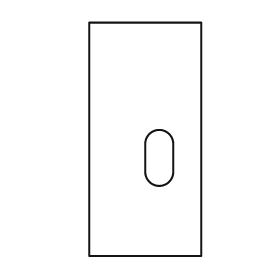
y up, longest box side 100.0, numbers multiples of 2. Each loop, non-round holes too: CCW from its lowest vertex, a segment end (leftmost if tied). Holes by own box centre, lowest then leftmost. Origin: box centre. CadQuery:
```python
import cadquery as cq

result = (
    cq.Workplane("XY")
    .moveTo(-24.0, -50.0)
    .lineTo(24.0, -50.0)
    .lineTo(24.0, 50.0)
    .lineTo(-24.0, 50.0)
    .close()
    .moveTo(0.0, -14.0)
    .threePointArc((6.0, -20.0), (12.0, -14.0))
    .lineTo(12.0, -2.0)
    .threePointArc((6.0, 4.0), (0.0, -2.0))
    .close()
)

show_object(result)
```